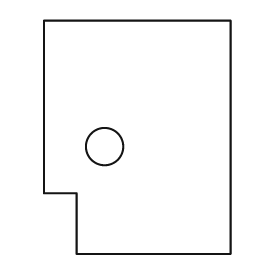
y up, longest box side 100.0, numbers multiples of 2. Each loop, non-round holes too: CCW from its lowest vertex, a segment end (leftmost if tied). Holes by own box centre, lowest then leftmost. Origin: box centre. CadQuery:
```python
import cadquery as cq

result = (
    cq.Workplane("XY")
    .moveTo(-26.0, -50.0)
    .lineTo(40.0, -50.0)
    .lineTo(40.0, 50.0)
    .lineTo(-40.0, 50.0)
    .lineTo(-40.0, -24.0)
    .lineTo(-26.0, -24.0)
    .close()
    .moveTo(-14.0, -4.0)
    .circle(8.0)
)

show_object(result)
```